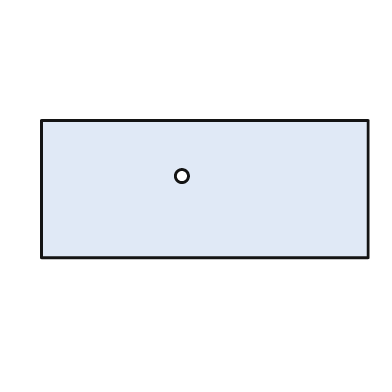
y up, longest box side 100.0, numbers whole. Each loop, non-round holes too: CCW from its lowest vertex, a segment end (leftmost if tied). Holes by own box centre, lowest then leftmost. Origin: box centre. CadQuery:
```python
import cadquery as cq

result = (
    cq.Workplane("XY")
    .moveTo(-50.0, -21.0)
    .lineTo(50.0, -21.0)
    .lineTo(50.0, 21.0)
    .lineTo(-50.0, 21.0)
    .close()
    .moveTo(-7.0, 4.0)
    .circle(2.0)
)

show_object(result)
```